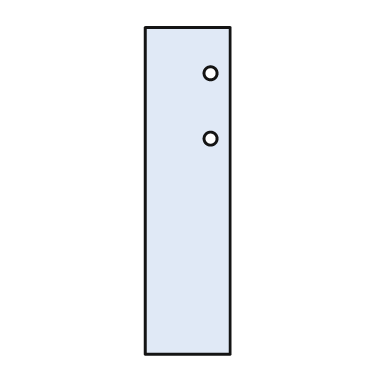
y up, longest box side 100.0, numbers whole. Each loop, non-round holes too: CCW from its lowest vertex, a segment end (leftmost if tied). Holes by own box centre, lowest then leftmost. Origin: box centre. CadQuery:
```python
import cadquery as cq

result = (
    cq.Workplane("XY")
    .moveTo(-13.0, -50.0)
    .lineTo(13.0, -50.0)
    .lineTo(13.0, 50.0)
    .lineTo(-13.0, 50.0)
    .close()
    .moveTo(7.0, 16.0)
    .circle(2.0)
    .moveTo(7.0, 36.0)
    .circle(2.0)
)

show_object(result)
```